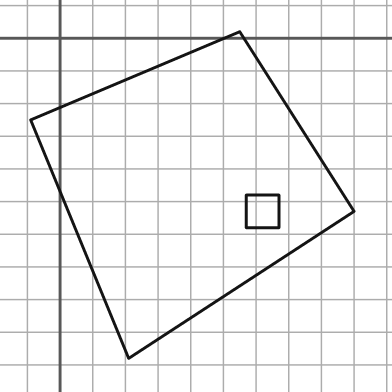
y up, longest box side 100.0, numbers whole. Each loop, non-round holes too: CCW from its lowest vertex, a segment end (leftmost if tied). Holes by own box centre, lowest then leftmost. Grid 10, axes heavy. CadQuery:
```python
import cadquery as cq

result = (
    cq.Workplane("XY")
    .moveTo(21.0, -98.0)
    .lineTo(90.0, -53.0)
    .lineTo(55.0, 2.0)
    .lineTo(-9.0, -25.0)
    .close()
    .moveTo(57.0, -58.0)
    .lineTo(67.0, -58.0)
    .lineTo(67.0, -48.0)
    .lineTo(57.0, -48.0)
    .close()
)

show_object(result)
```